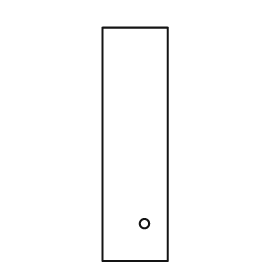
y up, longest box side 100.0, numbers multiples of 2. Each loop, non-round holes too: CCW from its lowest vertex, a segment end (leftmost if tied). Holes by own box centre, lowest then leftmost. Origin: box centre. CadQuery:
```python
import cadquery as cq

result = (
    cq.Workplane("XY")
    .moveTo(-14.0, -50.0)
    .lineTo(14.0, -50.0)
    .lineTo(14.0, 50.0)
    .lineTo(-14.0, 50.0)
    .close()
    .moveTo(4.0, -34.0)
    .circle(2.0)
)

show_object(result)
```